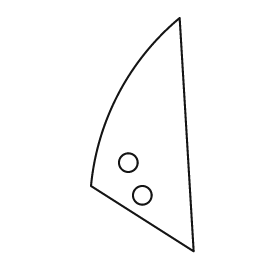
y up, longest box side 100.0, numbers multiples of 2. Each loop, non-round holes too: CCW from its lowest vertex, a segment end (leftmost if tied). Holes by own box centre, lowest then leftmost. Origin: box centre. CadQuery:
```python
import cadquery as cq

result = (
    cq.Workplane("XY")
    .moveTo(22.0, -50.0)
    .lineTo(16.0, 50.0)
    .threePointArc((-10.0, 18.0), (-22.0, -22.0))
    .close()
    .moveTo(0.0, -26.0)
    .circle(4.0)
    .moveTo(-6.0, -12.0)
    .circle(4.0)
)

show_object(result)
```